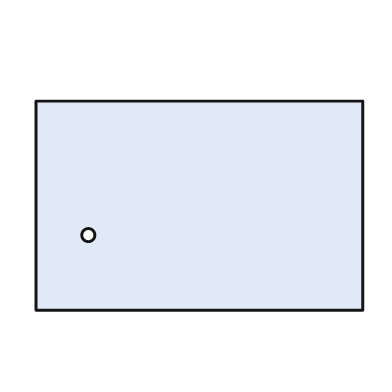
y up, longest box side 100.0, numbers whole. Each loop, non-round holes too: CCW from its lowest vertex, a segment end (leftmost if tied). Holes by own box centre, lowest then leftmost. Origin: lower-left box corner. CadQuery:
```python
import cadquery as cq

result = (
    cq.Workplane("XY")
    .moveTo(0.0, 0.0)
    .lineTo(100.0, 0.0)
    .lineTo(100.0, 64.0)
    .lineTo(0.0, 64.0)
    .close()
    .moveTo(16.0, 23.0)
    .circle(2.0)
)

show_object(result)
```